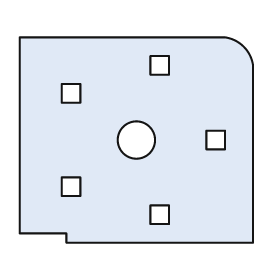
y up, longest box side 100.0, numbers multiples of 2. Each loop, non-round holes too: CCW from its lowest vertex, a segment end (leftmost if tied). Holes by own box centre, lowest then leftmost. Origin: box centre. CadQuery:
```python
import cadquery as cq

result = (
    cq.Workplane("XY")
    .moveTo(-30.0, -44.0)
    .lineTo(50.0, -44.0)
    .lineTo(50.0, 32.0)
    .threePointArc((46.0, 40.0), (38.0, 44.0))
    .lineTo(-50.0, 44.0)
    .lineTo(-50.0, -40.0)
    .lineTo(-30.0, -40.0)
    .close()
    .moveTo(6.0, -36.0)
    .lineTo(14.0, -36.0)
    .lineTo(14.0, -28.0)
    .lineTo(6.0, -28.0)
    .close()
    .moveTo(-32.0, -24.0)
    .lineTo(-24.0, -24.0)
    .lineTo(-24.0, -16.0)
    .lineTo(-32.0, -16.0)
    .close()
    .moveTo(0.0, 0.0)
    .circle(8.0)
    .moveTo(30.0, -4.0)
    .lineTo(38.0, -4.0)
    .lineTo(38.0, 4.0)
    .lineTo(30.0, 4.0)
    .close()
    .moveTo(-32.0, 16.0)
    .lineTo(-24.0, 16.0)
    .lineTo(-24.0, 24.0)
    .lineTo(-32.0, 24.0)
    .close()
    .moveTo(6.0, 28.0)
    .lineTo(14.0, 28.0)
    .lineTo(14.0, 36.0)
    .lineTo(6.0, 36.0)
    .close()
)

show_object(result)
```